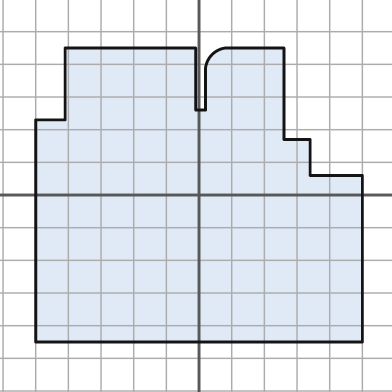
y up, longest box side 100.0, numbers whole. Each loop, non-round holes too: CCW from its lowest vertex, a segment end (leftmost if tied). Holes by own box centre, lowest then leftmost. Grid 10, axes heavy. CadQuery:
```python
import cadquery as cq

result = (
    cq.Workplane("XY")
    .moveTo(-50.0, -45.0)
    .lineTo(50.0, -45.0)
    .lineTo(50.0, 6.0)
    .lineTo(34.0, 6.0)
    .lineTo(34.0, 17.0)
    .lineTo(26.0, 17.0)
    .lineTo(26.0, 45.0)
    .lineTo(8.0, 45.0)
    .threePointArc((4.0, 43.0), (2.0, 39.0))
    .lineTo(2.0, 26.0)
    .lineTo(-1.0, 26.0)
    .lineTo(-1.0, 45.0)
    .lineTo(-41.0, 45.0)
    .lineTo(-41.0, 23.0)
    .lineTo(-50.0, 23.0)
    .close()
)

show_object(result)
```